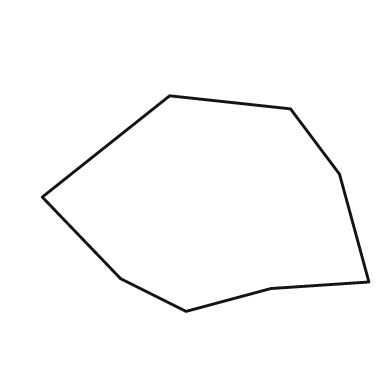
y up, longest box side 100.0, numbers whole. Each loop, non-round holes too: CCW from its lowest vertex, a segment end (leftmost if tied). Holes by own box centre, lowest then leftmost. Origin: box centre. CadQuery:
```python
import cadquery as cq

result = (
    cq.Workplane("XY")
    .moveTo(-6.0, -33.0)
    .lineTo(20.0, -26.0)
    .lineTo(50.0, -24.0)
    .lineTo(41.0, 9.0)
    .lineTo(26.0, 29.0)
    .lineTo(-11.0, 33.0)
    .lineTo(-50.0, 2.0)
    .lineTo(-26.0, -23.0)
    .close()
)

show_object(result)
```